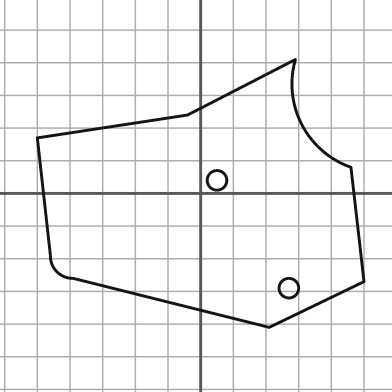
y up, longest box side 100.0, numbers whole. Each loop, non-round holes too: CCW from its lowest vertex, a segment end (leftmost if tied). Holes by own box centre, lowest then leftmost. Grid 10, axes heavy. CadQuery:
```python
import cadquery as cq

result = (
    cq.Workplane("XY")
    .moveTo(21.0, -41.0)
    .lineTo(50.0, -27.0)
    .lineTo(46.0, 8.0)
    .threePointArc((31.0, 21.0), (29.0, 41.0))
    .lineTo(-4.0, 24.0)
    .lineTo(-50.0, 17.0)
    .lineTo(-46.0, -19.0)
    .threePointArc((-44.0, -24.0), (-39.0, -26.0))
    .close()
    .moveTo(27.0, -29.0)
    .circle(3.0)
    .moveTo(5.0, 4.0)
    .circle(3.0)
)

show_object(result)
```